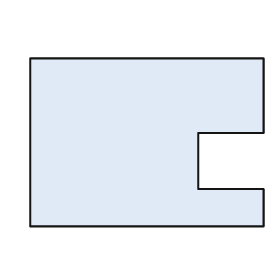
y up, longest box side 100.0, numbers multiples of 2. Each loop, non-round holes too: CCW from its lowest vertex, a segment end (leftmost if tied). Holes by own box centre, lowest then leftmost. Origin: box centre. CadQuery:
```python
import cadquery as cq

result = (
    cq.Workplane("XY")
    .moveTo(-50.0, -36.0)
    .lineTo(50.0, -36.0)
    .lineTo(50.0, -20.0)
    .lineTo(22.0, -20.0)
    .lineTo(22.0, 4.0)
    .lineTo(50.0, 4.0)
    .lineTo(50.0, 36.0)
    .lineTo(-50.0, 36.0)
    .close()
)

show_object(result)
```